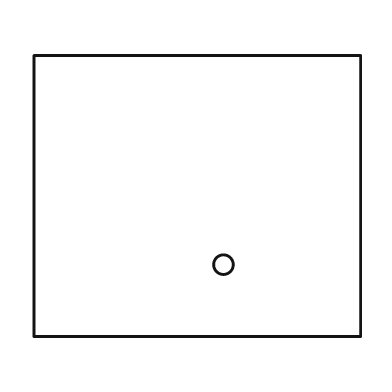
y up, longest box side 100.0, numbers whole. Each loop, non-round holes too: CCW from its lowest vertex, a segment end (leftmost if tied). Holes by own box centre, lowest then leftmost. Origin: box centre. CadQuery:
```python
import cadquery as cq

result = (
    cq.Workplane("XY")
    .moveTo(-50.0, -43.0)
    .lineTo(50.0, -43.0)
    .lineTo(50.0, 43.0)
    .lineTo(-50.0, 43.0)
    .close()
    .moveTo(8.0, -21.0)
    .circle(3.0)
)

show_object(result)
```